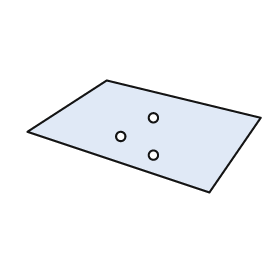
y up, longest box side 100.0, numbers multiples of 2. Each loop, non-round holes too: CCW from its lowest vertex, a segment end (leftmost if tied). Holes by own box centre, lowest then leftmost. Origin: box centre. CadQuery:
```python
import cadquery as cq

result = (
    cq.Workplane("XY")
    .moveTo(28.0, -24.0)
    .lineTo(50.0, 8.0)
    .lineTo(-16.0, 24.0)
    .lineTo(-50.0, 2.0)
    .close()
    .moveTo(4.0, -8.0)
    .circle(2.0)
    .moveTo(-10.0, 0.0)
    .circle(2.0)
    .moveTo(4.0, 8.0)
    .circle(2.0)
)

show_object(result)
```